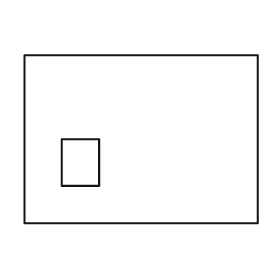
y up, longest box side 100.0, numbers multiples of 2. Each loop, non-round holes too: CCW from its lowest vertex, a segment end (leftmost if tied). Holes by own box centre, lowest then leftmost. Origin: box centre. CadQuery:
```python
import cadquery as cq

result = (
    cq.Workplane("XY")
    .moveTo(-50.0, -36.0)
    .lineTo(50.0, -36.0)
    .lineTo(50.0, 36.0)
    .lineTo(-50.0, 36.0)
    .close()
    .moveTo(-34.0, -20.0)
    .lineTo(-18.0, -20.0)
    .lineTo(-18.0, 0.0)
    .lineTo(-34.0, 0.0)
    .close()
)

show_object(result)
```